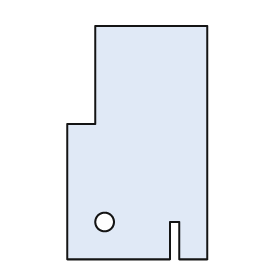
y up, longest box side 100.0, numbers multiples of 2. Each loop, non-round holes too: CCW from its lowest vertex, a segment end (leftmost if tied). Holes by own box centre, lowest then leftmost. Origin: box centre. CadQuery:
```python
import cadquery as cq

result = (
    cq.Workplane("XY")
    .moveTo(-30.0, -50.0)
    .lineTo(14.0, -50.0)
    .lineTo(14.0, -34.0)
    .lineTo(18.0, -34.0)
    .lineTo(18.0, -50.0)
    .lineTo(30.0, -50.0)
    .lineTo(30.0, 50.0)
    .lineTo(-18.0, 50.0)
    .lineTo(-18.0, 8.0)
    .lineTo(-30.0, 8.0)
    .close()
    .moveTo(-14.0, -34.0)
    .circle(4.0)
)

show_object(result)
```